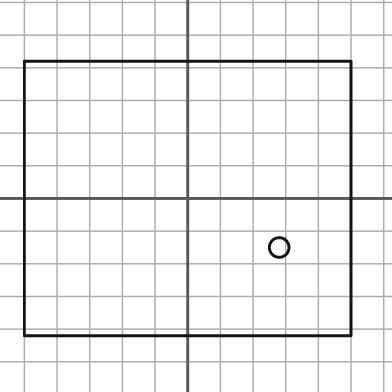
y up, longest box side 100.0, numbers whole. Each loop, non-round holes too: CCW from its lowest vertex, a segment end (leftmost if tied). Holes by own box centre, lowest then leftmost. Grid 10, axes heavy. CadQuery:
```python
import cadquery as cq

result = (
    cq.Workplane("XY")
    .moveTo(-50.0, -42.0)
    .lineTo(50.0, -42.0)
    .lineTo(50.0, 42.0)
    .lineTo(-50.0, 42.0)
    .close()
    .moveTo(28.0, -15.0)
    .circle(3.0)
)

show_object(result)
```